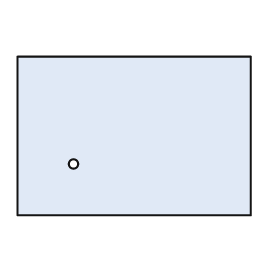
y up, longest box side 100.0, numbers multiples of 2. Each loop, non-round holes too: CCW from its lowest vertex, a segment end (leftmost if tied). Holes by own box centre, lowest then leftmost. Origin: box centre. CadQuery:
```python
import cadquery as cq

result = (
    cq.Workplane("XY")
    .moveTo(-50.0, -34.0)
    .lineTo(50.0, -34.0)
    .lineTo(50.0, 34.0)
    .lineTo(-50.0, 34.0)
    .close()
    .moveTo(-26.0, -12.0)
    .circle(2.0)
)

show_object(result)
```